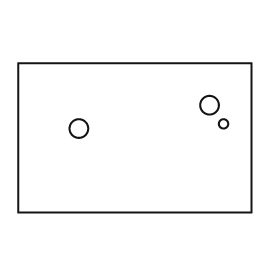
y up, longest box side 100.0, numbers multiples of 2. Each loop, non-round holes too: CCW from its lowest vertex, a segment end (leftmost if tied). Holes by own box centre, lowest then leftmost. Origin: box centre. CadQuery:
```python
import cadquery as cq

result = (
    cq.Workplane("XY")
    .moveTo(-50.0, -32.0)
    .lineTo(50.0, -32.0)
    .lineTo(50.0, 32.0)
    .lineTo(-50.0, 32.0)
    .close()
    .moveTo(-24.0, 4.0)
    .circle(4.0)
    .moveTo(38.0, 6.0)
    .circle(2.0)
    .moveTo(32.0, 14.0)
    .circle(4.0)
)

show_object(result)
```